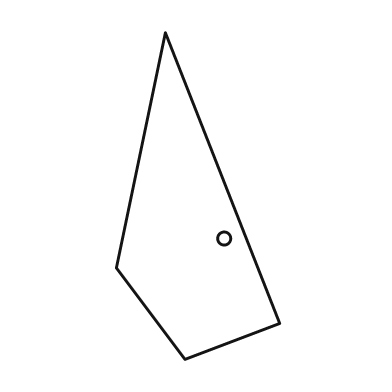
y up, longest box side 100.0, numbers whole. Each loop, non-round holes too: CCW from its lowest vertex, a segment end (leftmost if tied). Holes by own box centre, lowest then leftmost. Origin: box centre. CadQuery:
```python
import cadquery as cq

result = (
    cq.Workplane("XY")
    .moveTo(-4.0, -50.0)
    .lineTo(25.0, -39.0)
    .lineTo(-10.0, 50.0)
    .lineTo(-25.0, -22.0)
    .close()
    .moveTo(8.0, -13.0)
    .circle(2.0)
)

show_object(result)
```